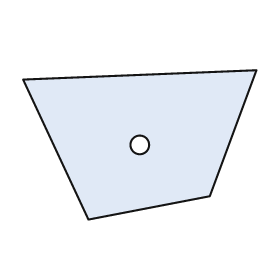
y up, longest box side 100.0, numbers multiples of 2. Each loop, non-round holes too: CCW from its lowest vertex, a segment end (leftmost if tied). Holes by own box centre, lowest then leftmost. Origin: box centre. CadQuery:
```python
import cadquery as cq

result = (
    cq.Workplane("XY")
    .moveTo(-22.0, -32.0)
    .lineTo(30.0, -22.0)
    .lineTo(50.0, 32.0)
    .lineTo(-50.0, 28.0)
    .close()
    .moveTo(0.0, 0.0)
    .circle(4.0)
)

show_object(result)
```